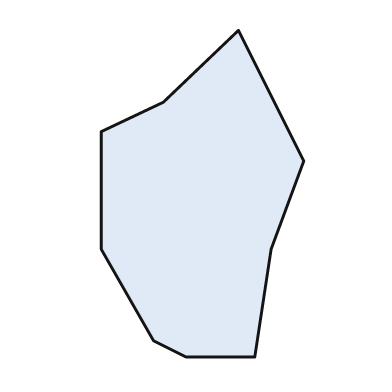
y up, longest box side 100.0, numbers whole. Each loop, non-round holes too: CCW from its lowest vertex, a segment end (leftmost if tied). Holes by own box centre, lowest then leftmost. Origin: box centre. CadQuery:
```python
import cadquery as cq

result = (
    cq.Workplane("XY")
    .moveTo(-5.0, -50.0)
    .lineTo(16.0, -50.0)
    .lineTo(21.0, -17.0)
    .lineTo(31.0, 10.0)
    .lineTo(11.0, 50.0)
    .lineTo(-12.0, 28.0)
    .lineTo(-31.0, 19.0)
    .lineTo(-31.0, -17.0)
    .lineTo(-15.0, -45.0)
    .close()
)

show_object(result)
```